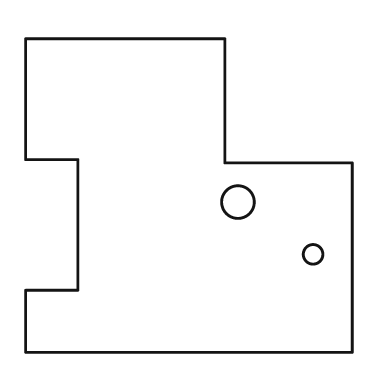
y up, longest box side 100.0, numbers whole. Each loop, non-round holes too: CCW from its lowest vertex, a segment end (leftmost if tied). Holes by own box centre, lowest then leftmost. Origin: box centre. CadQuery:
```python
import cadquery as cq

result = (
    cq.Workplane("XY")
    .moveTo(-50.0, -48.0)
    .lineTo(50.0, -48.0)
    .lineTo(50.0, 10.0)
    .lineTo(11.0, 10.0)
    .lineTo(11.0, 48.0)
    .lineTo(-50.0, 48.0)
    .lineTo(-50.0, 11.0)
    .lineTo(-34.0, 11.0)
    .lineTo(-34.0, -29.0)
    .lineTo(-50.0, -29.0)
    .close()
    .moveTo(38.0, -18.0)
    .circle(3.0)
    .moveTo(15.0, -2.0)
    .circle(5.0)
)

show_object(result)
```